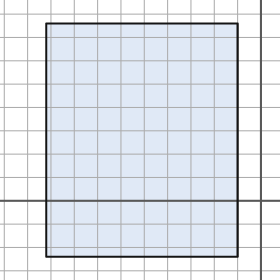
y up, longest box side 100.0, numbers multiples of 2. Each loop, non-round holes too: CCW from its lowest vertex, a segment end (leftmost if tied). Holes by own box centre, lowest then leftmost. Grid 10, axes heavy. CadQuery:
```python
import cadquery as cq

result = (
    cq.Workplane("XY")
    .moveTo(-92.0, -24.0)
    .lineTo(-10.0, -24.0)
    .lineTo(-10.0, 76.0)
    .lineTo(-92.0, 76.0)
    .close()
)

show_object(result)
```